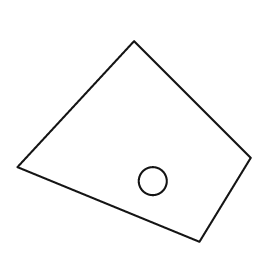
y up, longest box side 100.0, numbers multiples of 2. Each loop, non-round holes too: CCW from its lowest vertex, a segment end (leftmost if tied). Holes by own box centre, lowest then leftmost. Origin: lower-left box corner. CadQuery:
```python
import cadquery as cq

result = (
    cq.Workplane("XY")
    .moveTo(78.0, 0.0)
    .lineTo(100.0, 36.0)
    .lineTo(50.0, 86.0)
    .lineTo(0.0, 32.0)
    .close()
    .moveTo(58.0, 26.0)
    .circle(6.0)
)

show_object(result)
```